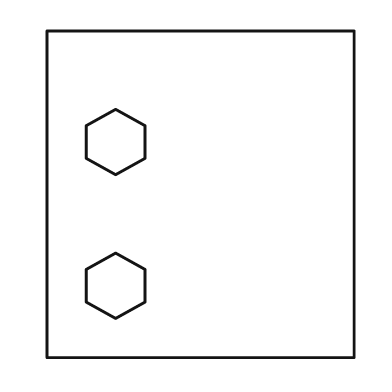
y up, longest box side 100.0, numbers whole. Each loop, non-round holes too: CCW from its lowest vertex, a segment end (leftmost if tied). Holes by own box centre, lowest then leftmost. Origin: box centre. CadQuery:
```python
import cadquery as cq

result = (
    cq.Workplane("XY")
    .moveTo(-47.0, -50.0)
    .lineTo(47.0, -50.0)
    .lineTo(47.0, 50.0)
    .lineTo(-47.0, 50.0)
    .close()
    .moveTo(-26.0, -38.0)
    .lineTo(-17.0, -33.0)
    .lineTo(-17.0, -23.0)
    .lineTo(-26.0, -18.0)
    .lineTo(-35.0, -23.0)
    .lineTo(-35.0, -33.0)
    .close()
    .moveTo(-26.0, 6.0)
    .lineTo(-17.0, 11.0)
    .lineTo(-17.0, 21.0)
    .lineTo(-26.0, 26.0)
    .lineTo(-35.0, 21.0)
    .lineTo(-35.0, 11.0)
    .close()
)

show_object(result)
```